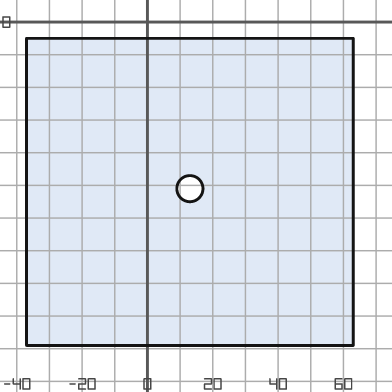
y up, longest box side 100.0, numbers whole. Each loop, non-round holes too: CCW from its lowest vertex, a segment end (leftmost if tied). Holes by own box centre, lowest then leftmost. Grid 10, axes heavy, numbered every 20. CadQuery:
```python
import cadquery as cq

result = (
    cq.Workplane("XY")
    .moveTo(-37.0, -99.0)
    .lineTo(63.0, -99.0)
    .lineTo(63.0, -5.0)
    .lineTo(-37.0, -5.0)
    .close()
    .moveTo(13.0, -51.0)
    .circle(4.0)
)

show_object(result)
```